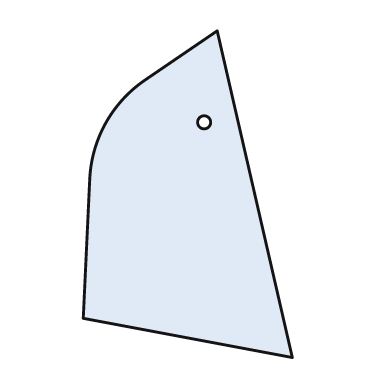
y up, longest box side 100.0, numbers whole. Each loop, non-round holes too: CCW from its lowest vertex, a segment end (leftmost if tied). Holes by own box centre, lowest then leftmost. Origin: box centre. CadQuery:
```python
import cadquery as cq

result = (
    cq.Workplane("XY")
    .moveTo(32.0, -50.0)
    .lineTo(9.0, 50.0)
    .lineTo(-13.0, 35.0)
    .threePointArc((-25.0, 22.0), (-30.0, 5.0))
    .lineTo(-32.0, -38.0)
    .close()
    .moveTo(5.0, 22.0)
    .circle(2.0)
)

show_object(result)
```